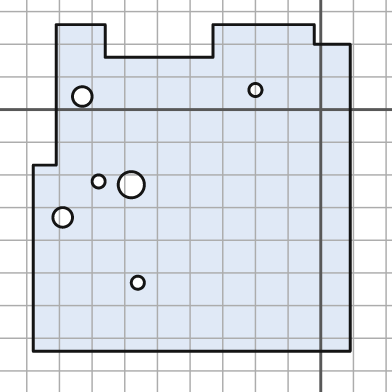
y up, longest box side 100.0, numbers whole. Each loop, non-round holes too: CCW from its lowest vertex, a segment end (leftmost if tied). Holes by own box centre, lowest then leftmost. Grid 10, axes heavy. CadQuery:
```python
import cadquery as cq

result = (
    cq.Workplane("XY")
    .moveTo(-88.0, -74.0)
    .lineTo(9.0, -74.0)
    .lineTo(9.0, 20.0)
    .lineTo(-2.0, 20.0)
    .lineTo(-2.0, 26.0)
    .lineTo(-33.0, 26.0)
    .lineTo(-33.0, 16.0)
    .lineTo(-66.0, 16.0)
    .lineTo(-66.0, 26.0)
    .lineTo(-81.0, 26.0)
    .lineTo(-81.0, -17.0)
    .lineTo(-88.0, -17.0)
    .close()
    .moveTo(-56.0, -53.0)
    .circle(2.0)
    .moveTo(-79.0, -33.0)
    .circle(3.0)
    .moveTo(-58.0, -23.0)
    .circle(4.0)
    .moveTo(-68.0, -22.0)
    .circle(2.0)
    .moveTo(-73.0, 4.0)
    .circle(3.0)
    .moveTo(-20.0, 6.0)
    .circle(2.0)
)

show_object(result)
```